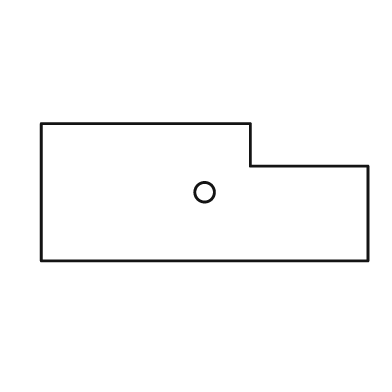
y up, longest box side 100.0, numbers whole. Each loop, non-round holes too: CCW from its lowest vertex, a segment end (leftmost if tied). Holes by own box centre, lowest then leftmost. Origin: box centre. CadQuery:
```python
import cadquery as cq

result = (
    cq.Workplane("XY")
    .moveTo(-50.0, -21.0)
    .lineTo(50.0, -21.0)
    .lineTo(50.0, 8.0)
    .lineTo(14.0, 8.0)
    .lineTo(14.0, 21.0)
    .lineTo(-50.0, 21.0)
    .close()
    .moveTo(0.0, 0.0)
    .circle(3.0)
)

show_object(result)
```